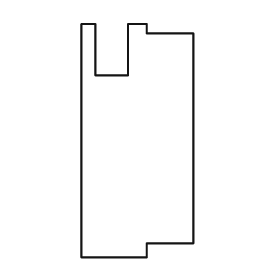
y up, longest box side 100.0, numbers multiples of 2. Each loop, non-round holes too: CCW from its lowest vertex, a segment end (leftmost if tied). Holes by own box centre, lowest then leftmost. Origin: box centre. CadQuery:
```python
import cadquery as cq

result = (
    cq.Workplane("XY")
    .moveTo(-24.0, -50.0)
    .lineTo(4.0, -50.0)
    .lineTo(4.0, -44.0)
    .lineTo(24.0, -44.0)
    .lineTo(24.0, 46.0)
    .lineTo(4.0, 46.0)
    .lineTo(4.0, 50.0)
    .lineTo(-4.0, 50.0)
    .lineTo(-4.0, 28.0)
    .lineTo(-18.0, 28.0)
    .lineTo(-18.0, 50.0)
    .lineTo(-24.0, 50.0)
    .close()
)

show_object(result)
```